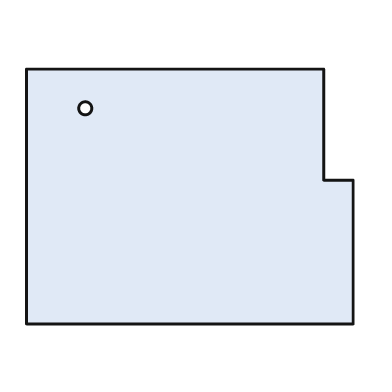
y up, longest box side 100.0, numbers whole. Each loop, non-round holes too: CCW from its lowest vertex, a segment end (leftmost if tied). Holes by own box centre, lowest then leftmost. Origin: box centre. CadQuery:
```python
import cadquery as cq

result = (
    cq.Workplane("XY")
    .moveTo(-50.0, -39.0)
    .lineTo(50.0, -39.0)
    .lineTo(50.0, 5.0)
    .lineTo(41.0, 5.0)
    .lineTo(41.0, 39.0)
    .lineTo(-50.0, 39.0)
    .close()
    .moveTo(-32.0, 27.0)
    .circle(2.0)
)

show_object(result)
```